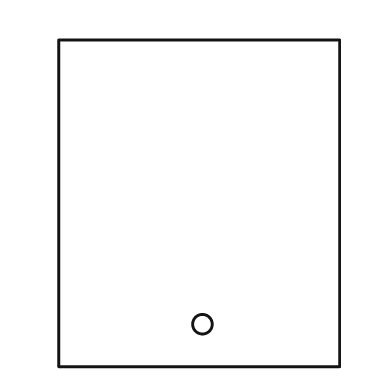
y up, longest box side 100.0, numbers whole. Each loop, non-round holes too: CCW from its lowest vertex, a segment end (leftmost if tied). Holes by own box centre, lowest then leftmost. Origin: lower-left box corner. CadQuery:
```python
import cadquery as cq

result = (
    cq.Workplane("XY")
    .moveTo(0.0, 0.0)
    .lineTo(86.0, 0.0)
    .lineTo(86.0, 100.0)
    .lineTo(0.0, 100.0)
    .close()
    .moveTo(44.0, 13.0)
    .circle(3.0)
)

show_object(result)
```